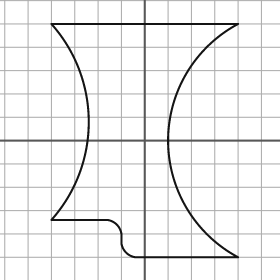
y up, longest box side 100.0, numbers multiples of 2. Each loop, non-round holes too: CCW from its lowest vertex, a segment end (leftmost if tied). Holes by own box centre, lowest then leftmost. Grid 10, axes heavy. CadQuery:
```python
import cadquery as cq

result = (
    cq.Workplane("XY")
    .moveTo(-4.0, -50.0)
    .lineTo(40.0, -50.0)
    .threePointArc((10.0, 0.0), (40.0, 50.0))
    .lineTo(-40.0, 50.0)
    .threePointArc((-24.0, 8.0), (-40.0, -34.0))
    .lineTo(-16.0, -34.0)
    .threePointArc((-12.0, -36.0), (-10.0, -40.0))
    .lineTo(-10.0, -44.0)
    .threePointArc((-8.0, -48.0), (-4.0, -50.0))
    .close()
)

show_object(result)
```